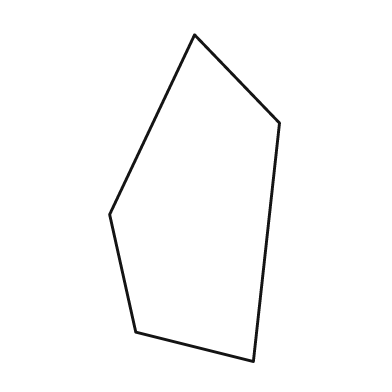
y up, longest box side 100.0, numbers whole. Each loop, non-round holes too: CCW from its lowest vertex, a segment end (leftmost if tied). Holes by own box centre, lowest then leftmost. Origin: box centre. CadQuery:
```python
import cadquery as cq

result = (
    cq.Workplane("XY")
    .moveTo(18.0, -50.0)
    .lineTo(26.0, 23.0)
    .lineTo(0.0, 50.0)
    .lineTo(-26.0, -5.0)
    .lineTo(-18.0, -41.0)
    .close()
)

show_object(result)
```